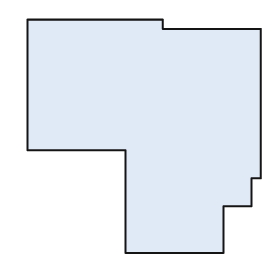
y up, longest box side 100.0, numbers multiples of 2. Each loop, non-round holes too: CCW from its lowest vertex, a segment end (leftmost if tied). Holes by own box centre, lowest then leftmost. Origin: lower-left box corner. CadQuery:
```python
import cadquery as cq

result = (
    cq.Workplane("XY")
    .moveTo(42.0, 0.0)
    .lineTo(84.0, 0.0)
    .lineTo(84.0, 20.0)
    .lineTo(96.0, 20.0)
    .lineTo(96.0, 32.0)
    .lineTo(100.0, 32.0)
    .lineTo(100.0, 96.0)
    .lineTo(58.0, 96.0)
    .lineTo(58.0, 100.0)
    .lineTo(0.0, 100.0)
    .lineTo(0.0, 44.0)
    .lineTo(42.0, 44.0)
    .close()
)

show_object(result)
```